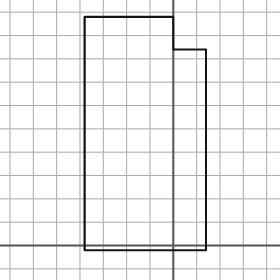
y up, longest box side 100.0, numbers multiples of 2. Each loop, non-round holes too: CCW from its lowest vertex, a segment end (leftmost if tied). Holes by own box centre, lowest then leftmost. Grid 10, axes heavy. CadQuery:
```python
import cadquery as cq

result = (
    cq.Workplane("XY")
    .moveTo(-38.0, -2.0)
    .lineTo(14.0, -2.0)
    .lineTo(14.0, 84.0)
    .lineTo(0.0, 84.0)
    .lineTo(0.0, 98.0)
    .lineTo(-38.0, 98.0)
    .close()
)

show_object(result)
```